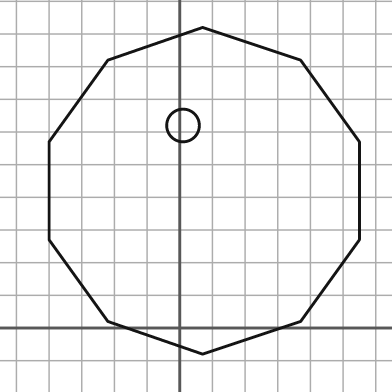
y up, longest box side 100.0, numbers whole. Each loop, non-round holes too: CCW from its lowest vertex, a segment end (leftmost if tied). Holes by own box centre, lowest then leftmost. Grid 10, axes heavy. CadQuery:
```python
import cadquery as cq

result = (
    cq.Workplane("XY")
    .moveTo(7.0, -8.0)
    .lineTo(37.0, 2.0)
    .lineTo(55.0, 27.0)
    .lineTo(55.0, 57.0)
    .lineTo(37.0, 82.0)
    .lineTo(7.0, 92.0)
    .lineTo(-22.0, 82.0)
    .lineTo(-40.0, 57.0)
    .lineTo(-40.0, 27.0)
    .lineTo(-22.0, 2.0)
    .close()
    .moveTo(1.0, 62.0)
    .circle(5.0)
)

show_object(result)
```